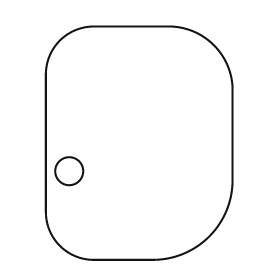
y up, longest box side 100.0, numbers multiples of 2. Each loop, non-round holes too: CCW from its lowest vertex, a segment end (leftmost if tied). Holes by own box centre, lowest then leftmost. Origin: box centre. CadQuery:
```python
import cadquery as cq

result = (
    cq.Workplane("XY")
    .moveTo(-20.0, -50.0)
    .lineTo(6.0, -50.0)
    .threePointArc((30.0, -40.0), (40.0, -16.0))
    .lineTo(40.0, 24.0)
    .threePointArc((32.0, 42.0), (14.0, 50.0))
    .lineTo(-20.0, 50.0)
    .threePointArc((-34.0, 44.0), (-40.0, 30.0))
    .lineTo(-40.0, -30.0)
    .threePointArc((-34.0, -44.0), (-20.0, -50.0))
    .close()
    .moveTo(-30.0, -12.0)
    .circle(6.0)
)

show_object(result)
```